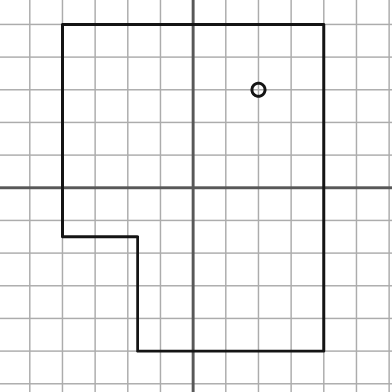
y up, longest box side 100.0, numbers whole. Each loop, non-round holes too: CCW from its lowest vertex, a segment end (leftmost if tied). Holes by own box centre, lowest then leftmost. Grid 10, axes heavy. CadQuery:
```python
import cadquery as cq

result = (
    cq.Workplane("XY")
    .moveTo(-17.0, -50.0)
    .lineTo(40.0, -50.0)
    .lineTo(40.0, 50.0)
    .lineTo(-40.0, 50.0)
    .lineTo(-40.0, -15.0)
    .lineTo(-17.0, -15.0)
    .close()
    .moveTo(20.0, 30.0)
    .circle(2.0)
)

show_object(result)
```